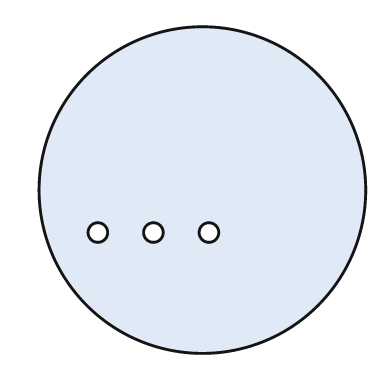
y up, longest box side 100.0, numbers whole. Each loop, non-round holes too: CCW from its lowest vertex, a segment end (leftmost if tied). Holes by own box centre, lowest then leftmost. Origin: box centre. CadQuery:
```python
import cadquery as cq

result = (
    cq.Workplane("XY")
    .moveTo(0.0, 0.0)
    .circle(50.0)
    .moveTo(-32.0, -13.0)
    .circle(3.0)
    .moveTo(-15.0, -13.0)
    .circle(3.0)
    .moveTo(2.0, -13.0)
    .circle(3.0)
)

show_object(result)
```